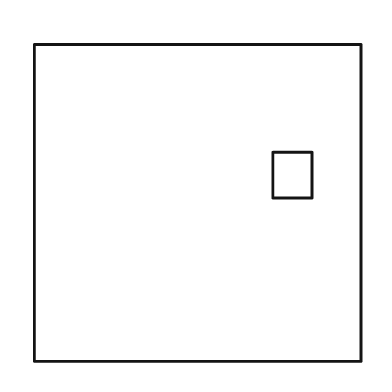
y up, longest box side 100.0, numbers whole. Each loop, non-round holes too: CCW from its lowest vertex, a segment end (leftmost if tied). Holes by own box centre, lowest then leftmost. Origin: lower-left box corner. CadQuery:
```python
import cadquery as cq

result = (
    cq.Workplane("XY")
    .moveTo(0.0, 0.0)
    .lineTo(100.0, 0.0)
    .lineTo(100.0, 97.0)
    .lineTo(0.0, 97.0)
    .close()
    .moveTo(73.0, 50.0)
    .lineTo(85.0, 50.0)
    .lineTo(85.0, 64.0)
    .lineTo(73.0, 64.0)
    .close()
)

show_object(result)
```